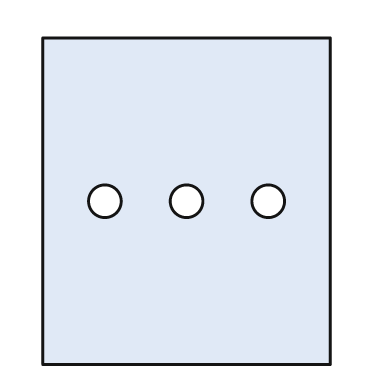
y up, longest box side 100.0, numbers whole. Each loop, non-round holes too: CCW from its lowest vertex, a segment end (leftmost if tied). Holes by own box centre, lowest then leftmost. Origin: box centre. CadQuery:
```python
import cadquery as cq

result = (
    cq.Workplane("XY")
    .moveTo(-44.0, -50.0)
    .lineTo(44.0, -50.0)
    .lineTo(44.0, 50.0)
    .lineTo(-44.0, 50.0)
    .close()
    .moveTo(-25.0, 0.0)
    .circle(5.0)
    .moveTo(0.0, 0.0)
    .circle(5.0)
    .moveTo(25.0, 0.0)
    .circle(5.0)
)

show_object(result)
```